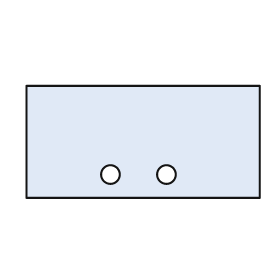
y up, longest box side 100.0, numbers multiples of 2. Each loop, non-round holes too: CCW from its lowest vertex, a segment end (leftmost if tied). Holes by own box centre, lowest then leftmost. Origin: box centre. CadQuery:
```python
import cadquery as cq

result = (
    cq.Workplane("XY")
    .moveTo(-50.0, -24.0)
    .lineTo(50.0, -24.0)
    .lineTo(50.0, 24.0)
    .lineTo(-50.0, 24.0)
    .close()
    .moveTo(-14.0, -14.0)
    .circle(4.0)
    .moveTo(10.0, -14.0)
    .circle(4.0)
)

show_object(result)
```